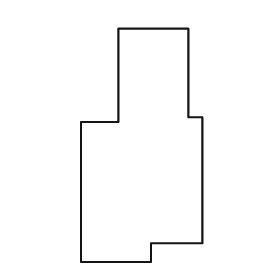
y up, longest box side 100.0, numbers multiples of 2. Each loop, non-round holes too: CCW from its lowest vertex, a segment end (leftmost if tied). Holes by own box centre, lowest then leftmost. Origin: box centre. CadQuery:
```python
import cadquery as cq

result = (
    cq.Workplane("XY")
    .moveTo(-26.0, -50.0)
    .lineTo(4.0, -50.0)
    .lineTo(4.0, -42.0)
    .lineTo(26.0, -42.0)
    .lineTo(26.0, 12.0)
    .lineTo(20.0, 12.0)
    .lineTo(20.0, 50.0)
    .lineTo(-10.0, 50.0)
    .lineTo(-10.0, 10.0)
    .lineTo(-26.0, 10.0)
    .close()
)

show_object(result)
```